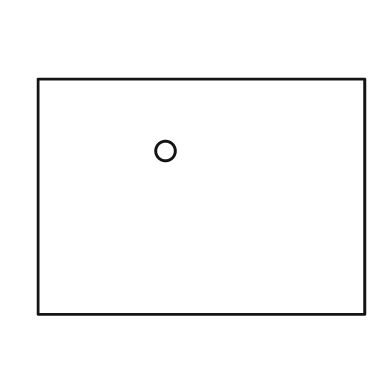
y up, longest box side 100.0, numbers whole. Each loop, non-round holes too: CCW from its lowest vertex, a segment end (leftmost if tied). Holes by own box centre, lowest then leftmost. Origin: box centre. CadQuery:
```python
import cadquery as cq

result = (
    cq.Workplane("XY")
    .moveTo(-50.0, -36.0)
    .lineTo(50.0, -36.0)
    .lineTo(50.0, 36.0)
    .lineTo(-50.0, 36.0)
    .close()
    .moveTo(-11.0, 14.0)
    .circle(3.0)
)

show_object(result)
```